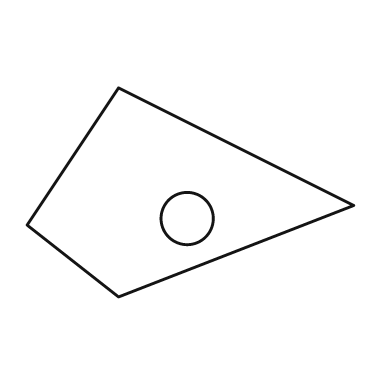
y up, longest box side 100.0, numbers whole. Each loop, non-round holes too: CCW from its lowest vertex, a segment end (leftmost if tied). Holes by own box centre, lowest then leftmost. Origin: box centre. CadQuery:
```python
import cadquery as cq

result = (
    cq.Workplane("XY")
    .moveTo(-22.0, -32.0)
    .lineTo(50.0, -4.0)
    .lineTo(-22.0, 32.0)
    .lineTo(-50.0, -10.0)
    .close()
    .moveTo(-1.0, -8.0)
    .circle(8.0)
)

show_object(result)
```